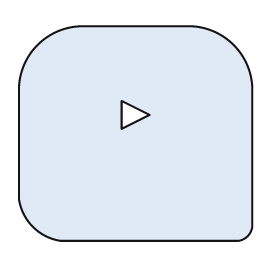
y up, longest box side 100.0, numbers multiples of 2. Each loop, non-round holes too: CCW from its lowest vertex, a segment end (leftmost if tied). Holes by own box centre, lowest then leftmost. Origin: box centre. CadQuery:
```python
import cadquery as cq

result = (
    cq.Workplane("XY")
    .moveTo(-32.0, -46.0)
    .lineTo(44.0, -46.0)
    .threePointArc((48.0, -44.0), (50.0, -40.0))
    .lineTo(50.0, 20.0)
    .threePointArc((42.0, 38.0), (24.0, 46.0))
    .lineTo(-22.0, 46.0)
    .threePointArc((-42.0, 38.0), (-50.0, 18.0))
    .lineTo(-50.0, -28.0)
    .threePointArc((-44.0, -40.0), (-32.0, -46.0))
    .close()
    .moveTo(-6.0, 2.0)
    .lineTo(6.0, 8.0)
    .lineTo(-6.0, 14.0)
    .close()
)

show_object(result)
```